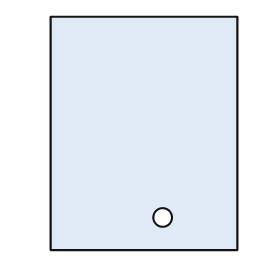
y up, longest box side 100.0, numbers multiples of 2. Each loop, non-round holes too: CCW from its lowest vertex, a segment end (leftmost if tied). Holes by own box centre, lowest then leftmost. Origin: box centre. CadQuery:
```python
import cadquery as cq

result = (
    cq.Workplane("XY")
    .moveTo(-40.0, -50.0)
    .lineTo(40.0, -50.0)
    .lineTo(40.0, 50.0)
    .lineTo(-40.0, 50.0)
    .close()
    .moveTo(8.0, -36.0)
    .circle(4.0)
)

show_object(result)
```